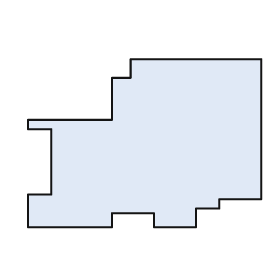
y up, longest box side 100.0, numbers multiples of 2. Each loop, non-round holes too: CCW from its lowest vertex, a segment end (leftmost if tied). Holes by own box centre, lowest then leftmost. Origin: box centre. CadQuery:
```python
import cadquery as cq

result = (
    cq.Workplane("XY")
    .moveTo(-50.0, -36.0)
    .lineTo(-14.0, -36.0)
    .lineTo(-14.0, -30.0)
    .lineTo(4.0, -30.0)
    .lineTo(4.0, -36.0)
    .lineTo(22.0, -36.0)
    .lineTo(22.0, -28.0)
    .lineTo(32.0, -28.0)
    .lineTo(32.0, -24.0)
    .lineTo(50.0, -24.0)
    .lineTo(50.0, 36.0)
    .lineTo(-6.0, 36.0)
    .lineTo(-6.0, 28.0)
    .lineTo(-14.0, 28.0)
    .lineTo(-14.0, 10.0)
    .lineTo(-50.0, 10.0)
    .lineTo(-50.0, 6.0)
    .lineTo(-40.0, 6.0)
    .lineTo(-40.0, -22.0)
    .lineTo(-50.0, -22.0)
    .close()
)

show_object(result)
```